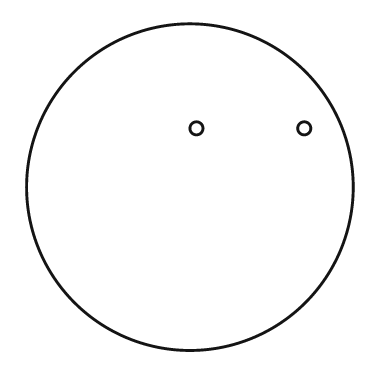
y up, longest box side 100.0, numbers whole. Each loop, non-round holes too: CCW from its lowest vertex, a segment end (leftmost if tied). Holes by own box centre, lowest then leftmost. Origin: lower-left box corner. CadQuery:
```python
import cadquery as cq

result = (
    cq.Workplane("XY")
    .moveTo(50.0, 50.0)
    .circle(50.0)
    .moveTo(52.0, 68.0)
    .circle(2.0)
    .moveTo(85.0, 68.0)
    .circle(2.0)
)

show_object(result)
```